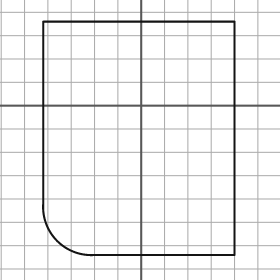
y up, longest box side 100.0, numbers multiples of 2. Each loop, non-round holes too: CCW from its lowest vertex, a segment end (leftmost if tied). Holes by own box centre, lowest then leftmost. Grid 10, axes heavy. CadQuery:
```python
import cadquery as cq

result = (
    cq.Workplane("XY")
    .moveTo(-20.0, -64.0)
    .lineTo(40.0, -64.0)
    .lineTo(40.0, 36.0)
    .lineTo(-42.0, 36.0)
    .lineTo(-42.0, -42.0)
    .threePointArc((-36.0, -58.0), (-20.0, -64.0))
    .close()
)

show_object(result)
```